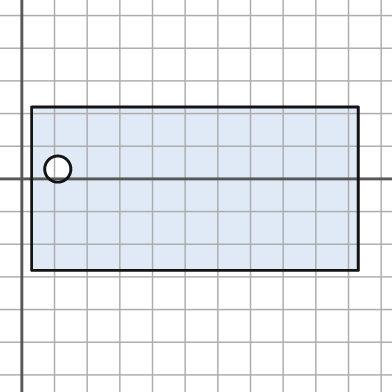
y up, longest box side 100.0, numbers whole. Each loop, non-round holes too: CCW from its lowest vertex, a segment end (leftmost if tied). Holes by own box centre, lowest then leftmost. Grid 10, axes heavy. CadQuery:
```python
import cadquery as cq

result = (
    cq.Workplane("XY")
    .moveTo(3.0, -28.0)
    .lineTo(103.0, -28.0)
    .lineTo(103.0, 22.0)
    .lineTo(3.0, 22.0)
    .close()
    .moveTo(11.0, 3.0)
    .circle(4.0)
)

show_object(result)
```